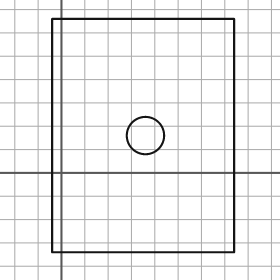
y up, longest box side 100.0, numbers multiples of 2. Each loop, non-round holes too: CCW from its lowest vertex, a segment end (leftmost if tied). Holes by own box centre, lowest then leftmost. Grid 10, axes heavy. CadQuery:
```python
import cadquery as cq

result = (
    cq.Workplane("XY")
    .moveTo(-4.0, -34.0)
    .lineTo(74.0, -34.0)
    .lineTo(74.0, 66.0)
    .lineTo(-4.0, 66.0)
    .close()
    .moveTo(36.0, 16.0)
    .circle(8.0)
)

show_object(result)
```